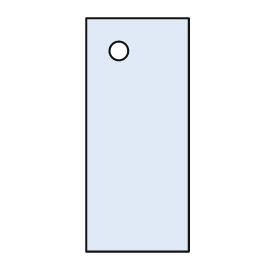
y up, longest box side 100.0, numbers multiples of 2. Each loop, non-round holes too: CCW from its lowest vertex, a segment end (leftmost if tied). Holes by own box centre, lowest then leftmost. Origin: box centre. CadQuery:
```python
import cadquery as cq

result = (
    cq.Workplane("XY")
    .moveTo(-22.0, -50.0)
    .lineTo(22.0, -50.0)
    .lineTo(22.0, 50.0)
    .lineTo(-22.0, 50.0)
    .close()
    .moveTo(-8.0, 36.0)
    .circle(4.0)
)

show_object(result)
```